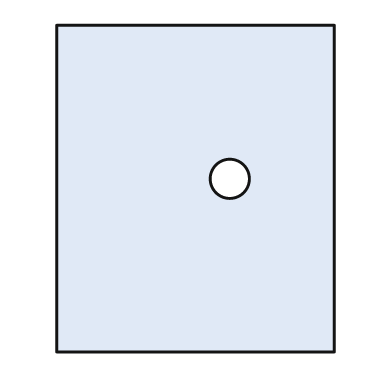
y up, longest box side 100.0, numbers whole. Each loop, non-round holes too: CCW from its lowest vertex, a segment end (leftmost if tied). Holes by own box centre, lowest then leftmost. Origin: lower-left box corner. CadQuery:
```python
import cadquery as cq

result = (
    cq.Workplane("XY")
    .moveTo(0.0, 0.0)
    .lineTo(85.0, 0.0)
    .lineTo(85.0, 100.0)
    .lineTo(0.0, 100.0)
    .close()
    .moveTo(53.0, 53.0)
    .circle(6.0)
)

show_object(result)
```